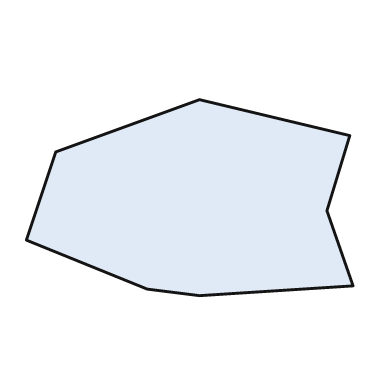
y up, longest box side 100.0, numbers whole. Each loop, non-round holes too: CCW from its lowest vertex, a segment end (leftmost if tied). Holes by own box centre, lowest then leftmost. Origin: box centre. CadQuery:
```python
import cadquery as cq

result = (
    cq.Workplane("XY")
    .moveTo(3.0, -30.0)
    .lineTo(50.0, -27.0)
    .lineTo(42.0, -4.0)
    .lineTo(49.0, 19.0)
    .lineTo(3.0, 30.0)
    .lineTo(-41.0, 14.0)
    .lineTo(-50.0, -13.0)
    .lineTo(-13.0, -28.0)
    .close()
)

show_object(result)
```